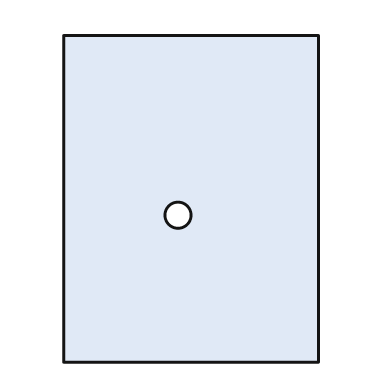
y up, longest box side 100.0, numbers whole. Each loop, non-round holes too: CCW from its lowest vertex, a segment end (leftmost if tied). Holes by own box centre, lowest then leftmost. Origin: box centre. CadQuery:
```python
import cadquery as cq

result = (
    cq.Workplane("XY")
    .moveTo(-39.0, -50.0)
    .lineTo(39.0, -50.0)
    .lineTo(39.0, 50.0)
    .lineTo(-39.0, 50.0)
    .close()
    .moveTo(-4.0, -5.0)
    .circle(4.0)
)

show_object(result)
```